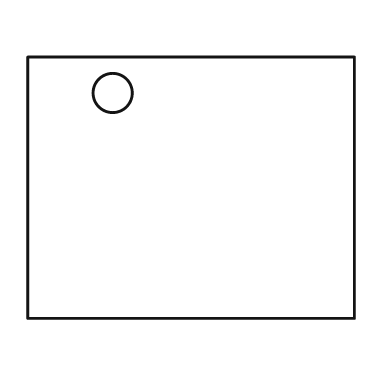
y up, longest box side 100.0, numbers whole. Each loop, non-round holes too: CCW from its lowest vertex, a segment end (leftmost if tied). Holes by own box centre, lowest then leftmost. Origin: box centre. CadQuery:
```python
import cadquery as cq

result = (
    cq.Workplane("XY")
    .moveTo(-50.0, -40.0)
    .lineTo(50.0, -40.0)
    .lineTo(50.0, 40.0)
    .lineTo(-50.0, 40.0)
    .close()
    .moveTo(-24.0, 29.0)
    .circle(6.0)
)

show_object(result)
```